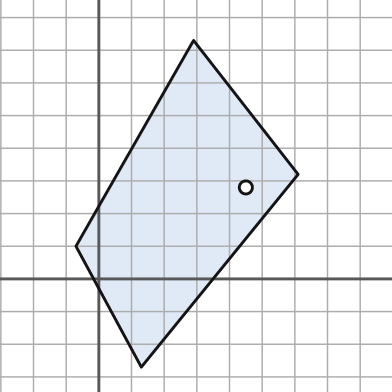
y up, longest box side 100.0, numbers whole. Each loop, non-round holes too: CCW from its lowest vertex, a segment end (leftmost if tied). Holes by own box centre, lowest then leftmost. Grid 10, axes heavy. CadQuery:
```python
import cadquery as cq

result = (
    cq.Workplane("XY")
    .moveTo(13.0, -27.0)
    .lineTo(61.0, 32.0)
    .lineTo(29.0, 73.0)
    .lineTo(-7.0, 10.0)
    .close()
    .moveTo(45.0, 28.0)
    .circle(2.0)
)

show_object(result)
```